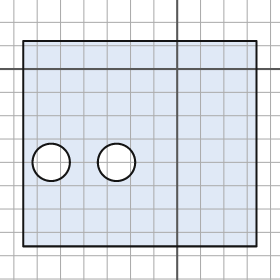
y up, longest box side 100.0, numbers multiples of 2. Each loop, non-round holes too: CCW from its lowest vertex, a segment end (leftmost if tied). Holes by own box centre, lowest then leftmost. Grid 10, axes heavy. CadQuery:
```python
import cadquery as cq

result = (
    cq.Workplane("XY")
    .moveTo(-66.0, -76.0)
    .lineTo(34.0, -76.0)
    .lineTo(34.0, 12.0)
    .lineTo(-66.0, 12.0)
    .close()
    .moveTo(-54.0, -40.0)
    .circle(8.0)
    .moveTo(-26.0, -40.0)
    .circle(8.0)
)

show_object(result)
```